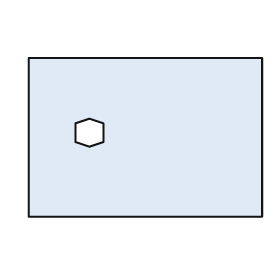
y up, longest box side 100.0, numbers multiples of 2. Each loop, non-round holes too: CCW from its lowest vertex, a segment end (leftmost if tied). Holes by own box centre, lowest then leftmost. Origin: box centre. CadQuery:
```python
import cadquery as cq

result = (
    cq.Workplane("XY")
    .moveTo(-50.0, -34.0)
    .lineTo(50.0, -34.0)
    .lineTo(50.0, 34.0)
    .lineTo(-50.0, 34.0)
    .close()
    .moveTo(-24.0, -4.0)
    .lineTo(-18.0, -2.0)
    .lineTo(-18.0, 6.0)
    .lineTo(-24.0, 8.0)
    .lineTo(-30.0, 6.0)
    .lineTo(-30.0, -2.0)
    .close()
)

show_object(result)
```